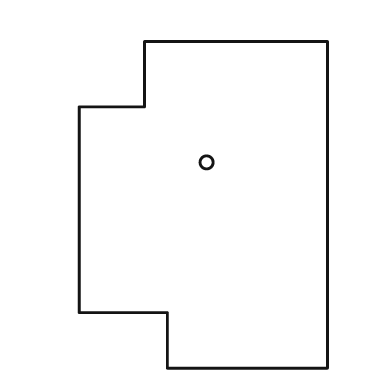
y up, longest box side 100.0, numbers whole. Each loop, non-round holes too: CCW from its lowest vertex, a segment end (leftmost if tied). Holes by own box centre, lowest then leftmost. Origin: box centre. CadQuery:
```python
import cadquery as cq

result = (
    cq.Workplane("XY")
    .moveTo(-11.0, -50.0)
    .lineTo(38.0, -50.0)
    .lineTo(38.0, 50.0)
    .lineTo(-18.0, 50.0)
    .lineTo(-18.0, 30.0)
    .lineTo(-38.0, 30.0)
    .lineTo(-38.0, -33.0)
    .lineTo(-11.0, -33.0)
    .close()
    .moveTo(1.0, 13.0)
    .circle(2.0)
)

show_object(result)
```